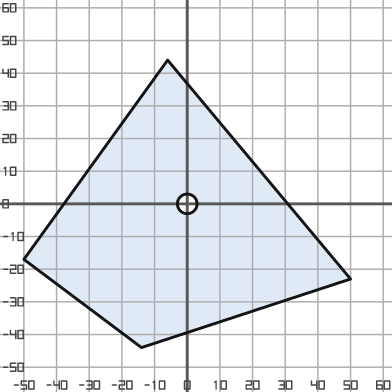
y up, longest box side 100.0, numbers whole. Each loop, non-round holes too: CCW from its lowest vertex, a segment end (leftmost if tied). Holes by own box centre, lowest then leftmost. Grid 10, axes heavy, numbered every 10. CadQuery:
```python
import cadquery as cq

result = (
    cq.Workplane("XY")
    .moveTo(-14.0, -44.0)
    .lineTo(50.0, -23.0)
    .lineTo(-6.0, 44.0)
    .lineTo(-50.0, -17.0)
    .close()
    .moveTo(0.0, 0.0)
    .circle(3.0)
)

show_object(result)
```